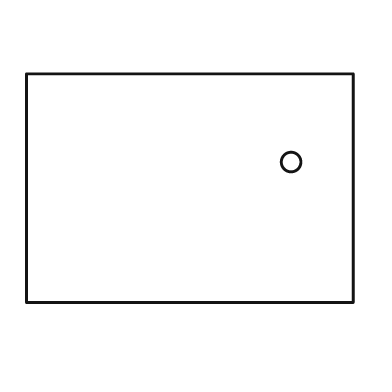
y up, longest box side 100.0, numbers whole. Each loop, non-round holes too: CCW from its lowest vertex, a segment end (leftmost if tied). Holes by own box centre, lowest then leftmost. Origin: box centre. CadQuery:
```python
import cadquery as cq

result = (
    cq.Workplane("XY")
    .moveTo(-50.0, -35.0)
    .lineTo(50.0, -35.0)
    .lineTo(50.0, 35.0)
    .lineTo(-50.0, 35.0)
    .close()
    .moveTo(31.0, 8.0)
    .circle(3.0)
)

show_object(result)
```